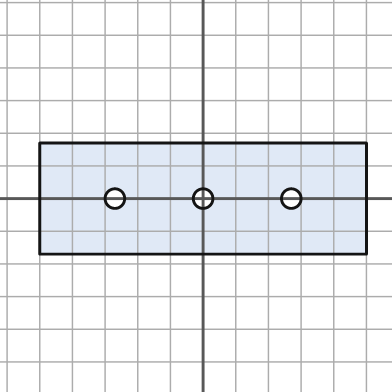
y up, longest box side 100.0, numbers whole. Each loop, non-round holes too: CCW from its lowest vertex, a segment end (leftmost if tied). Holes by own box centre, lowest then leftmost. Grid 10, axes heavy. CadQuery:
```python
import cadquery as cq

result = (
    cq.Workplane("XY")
    .moveTo(-50.0, -17.0)
    .lineTo(50.0, -17.0)
    .lineTo(50.0, 17.0)
    .lineTo(-50.0, 17.0)
    .close()
    .moveTo(-27.0, 0.0)
    .circle(3.0)
    .moveTo(0.0, 0.0)
    .circle(3.0)
    .moveTo(27.0, 0.0)
    .circle(3.0)
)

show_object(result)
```